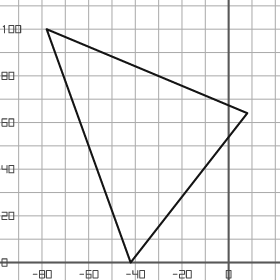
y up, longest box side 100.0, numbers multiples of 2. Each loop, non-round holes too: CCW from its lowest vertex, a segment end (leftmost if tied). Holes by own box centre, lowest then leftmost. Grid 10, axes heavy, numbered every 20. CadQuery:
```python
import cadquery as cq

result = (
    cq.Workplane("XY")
    .moveTo(-42.0, 0.0)
    .lineTo(8.0, 64.0)
    .lineTo(-78.0, 100.0)
    .close()
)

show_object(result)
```